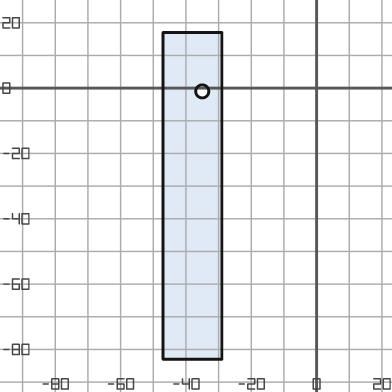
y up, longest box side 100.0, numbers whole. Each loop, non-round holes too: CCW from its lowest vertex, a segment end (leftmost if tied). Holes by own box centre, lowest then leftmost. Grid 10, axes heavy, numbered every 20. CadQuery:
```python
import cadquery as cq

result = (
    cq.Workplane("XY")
    .moveTo(-47.0, -83.0)
    .lineTo(-29.0, -83.0)
    .lineTo(-29.0, 17.0)
    .lineTo(-47.0, 17.0)
    .close()
    .moveTo(-35.0, -1.0)
    .circle(2.0)
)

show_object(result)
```